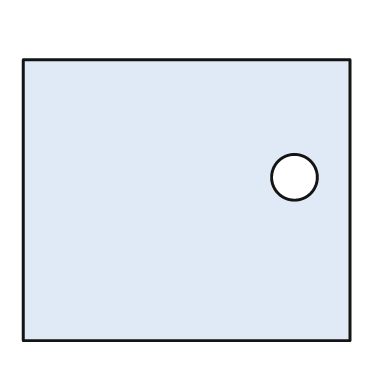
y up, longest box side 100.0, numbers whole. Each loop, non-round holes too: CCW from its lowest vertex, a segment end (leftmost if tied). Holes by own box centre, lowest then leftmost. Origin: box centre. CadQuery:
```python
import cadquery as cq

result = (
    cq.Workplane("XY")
    .moveTo(-50.0, -43.0)
    .lineTo(50.0, -43.0)
    .lineTo(50.0, 43.0)
    .lineTo(-50.0, 43.0)
    .close()
    .moveTo(33.0, 7.0)
    .circle(7.0)
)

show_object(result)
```